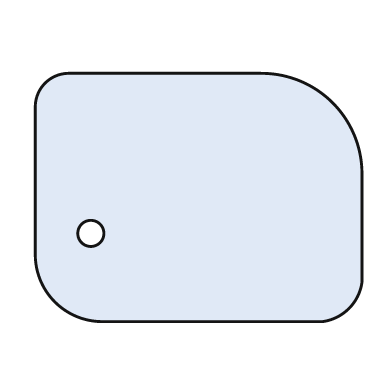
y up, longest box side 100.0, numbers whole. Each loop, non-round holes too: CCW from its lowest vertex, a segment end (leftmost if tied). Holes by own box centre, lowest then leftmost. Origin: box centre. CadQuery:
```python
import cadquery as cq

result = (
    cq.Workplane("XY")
    .moveTo(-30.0, -38.0)
    .lineTo(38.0, -38.0)
    .threePointArc((46.0, -34.0), (50.0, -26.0))
    .lineTo(50.0, 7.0)
    .threePointArc((41.0, 29.0), (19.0, 38.0))
    .lineTo(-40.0, 38.0)
    .threePointArc((-47.0, 35.0), (-50.0, 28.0))
    .lineTo(-50.0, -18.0)
    .threePointArc((-44.0, -32.0), (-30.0, -38.0))
    .close()
    .moveTo(-33.0, -11.0)
    .circle(4.0)
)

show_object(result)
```